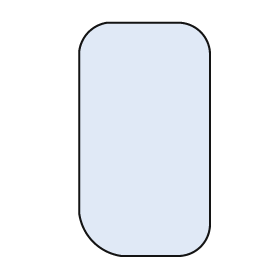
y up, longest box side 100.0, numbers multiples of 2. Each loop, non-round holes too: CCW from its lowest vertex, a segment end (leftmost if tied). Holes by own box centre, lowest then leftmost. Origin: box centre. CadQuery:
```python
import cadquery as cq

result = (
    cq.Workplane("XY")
    .moveTo(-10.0, -50.0)
    .lineTo(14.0, -50.0)
    .threePointArc((24.0, -46.0), (28.0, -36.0))
    .lineTo(28.0, 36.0)
    .threePointArc((24.0, 46.0), (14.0, 50.0))
    .lineTo(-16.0, 50.0)
    .threePointArc((-24.0, 46.0), (-28.0, 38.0))
    .lineTo(-28.0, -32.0)
    .threePointArc((-22.0, -44.0), (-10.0, -50.0))
    .close()
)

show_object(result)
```